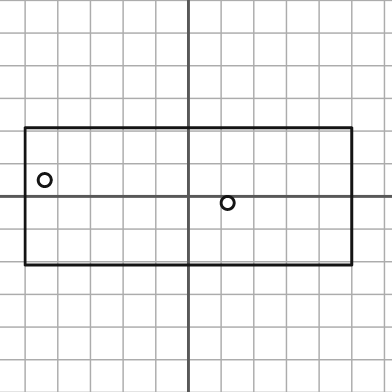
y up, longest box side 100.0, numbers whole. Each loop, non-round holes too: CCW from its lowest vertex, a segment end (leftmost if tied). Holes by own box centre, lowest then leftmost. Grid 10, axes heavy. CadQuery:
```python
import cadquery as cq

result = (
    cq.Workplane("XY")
    .moveTo(-50.0, -21.0)
    .lineTo(50.0, -21.0)
    .lineTo(50.0, 21.0)
    .lineTo(-50.0, 21.0)
    .close()
    .moveTo(12.0, -2.0)
    .circle(2.0)
    .moveTo(-44.0, 5.0)
    .circle(2.0)
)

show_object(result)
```